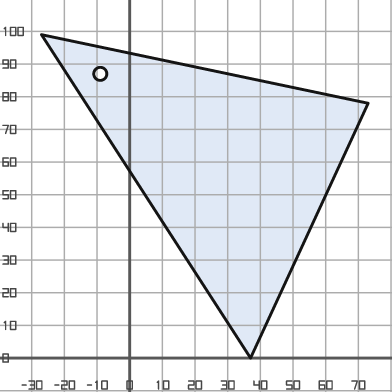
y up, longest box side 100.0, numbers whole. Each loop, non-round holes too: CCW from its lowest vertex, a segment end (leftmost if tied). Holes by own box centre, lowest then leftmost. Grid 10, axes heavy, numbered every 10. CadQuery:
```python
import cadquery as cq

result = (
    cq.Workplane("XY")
    .moveTo(37.0, 0.0)
    .lineTo(73.0, 78.0)
    .lineTo(-27.0, 99.0)
    .close()
    .moveTo(-9.0, 87.0)
    .circle(2.0)
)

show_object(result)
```